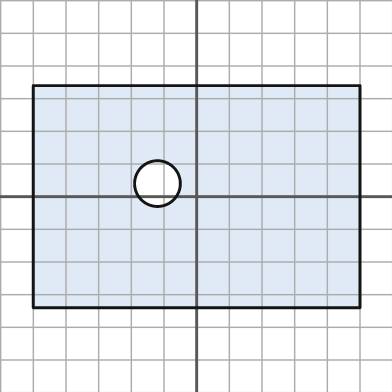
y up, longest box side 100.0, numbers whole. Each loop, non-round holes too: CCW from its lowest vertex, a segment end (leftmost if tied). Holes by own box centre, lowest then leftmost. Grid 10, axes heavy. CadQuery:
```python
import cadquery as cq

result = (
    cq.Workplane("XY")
    .moveTo(-50.0, -34.0)
    .lineTo(50.0, -34.0)
    .lineTo(50.0, 34.0)
    .lineTo(-50.0, 34.0)
    .close()
    .moveTo(-12.0, 4.0)
    .circle(7.0)
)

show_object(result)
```